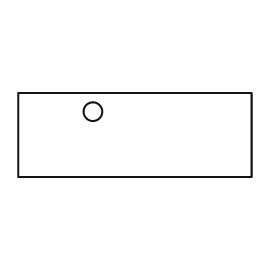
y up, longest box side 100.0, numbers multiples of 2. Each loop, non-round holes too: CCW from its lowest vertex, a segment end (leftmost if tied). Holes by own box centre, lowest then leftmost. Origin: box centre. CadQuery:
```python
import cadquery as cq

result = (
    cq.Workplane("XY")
    .moveTo(-50.0, -18.0)
    .lineTo(50.0, -18.0)
    .lineTo(50.0, 18.0)
    .lineTo(-50.0, 18.0)
    .close()
    .moveTo(-18.0, 10.0)
    .circle(4.0)
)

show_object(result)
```